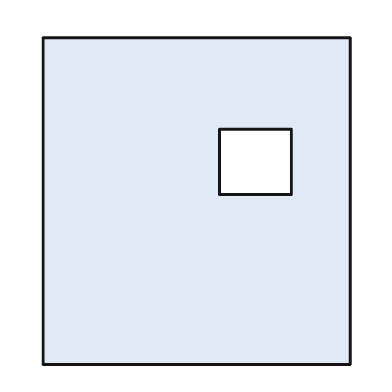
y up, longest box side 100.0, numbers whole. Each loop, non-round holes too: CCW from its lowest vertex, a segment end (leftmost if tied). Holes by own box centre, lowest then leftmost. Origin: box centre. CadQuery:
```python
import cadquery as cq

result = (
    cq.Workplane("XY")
    .moveTo(-47.0, -50.0)
    .lineTo(47.0, -50.0)
    .lineTo(47.0, 50.0)
    .lineTo(-47.0, 50.0)
    .close()
    .moveTo(7.0, 2.0)
    .lineTo(29.0, 2.0)
    .lineTo(29.0, 22.0)
    .lineTo(7.0, 22.0)
    .close()
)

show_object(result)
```